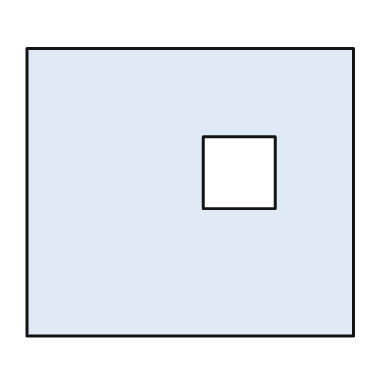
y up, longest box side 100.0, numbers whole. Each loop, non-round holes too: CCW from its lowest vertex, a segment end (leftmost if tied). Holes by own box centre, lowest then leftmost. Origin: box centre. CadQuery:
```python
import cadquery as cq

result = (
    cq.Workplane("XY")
    .moveTo(-50.0, -44.0)
    .lineTo(50.0, -44.0)
    .lineTo(50.0, 44.0)
    .lineTo(-50.0, 44.0)
    .close()
    .moveTo(4.0, -5.0)
    .lineTo(26.0, -5.0)
    .lineTo(26.0, 17.0)
    .lineTo(4.0, 17.0)
    .close()
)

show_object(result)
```